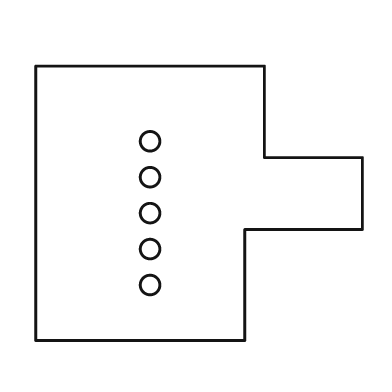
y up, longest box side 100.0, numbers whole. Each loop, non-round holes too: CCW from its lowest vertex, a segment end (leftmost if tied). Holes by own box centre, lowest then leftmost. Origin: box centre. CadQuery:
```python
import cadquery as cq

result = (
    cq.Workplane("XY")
    .moveTo(-50.0, -42.0)
    .lineTo(14.0, -42.0)
    .lineTo(14.0, -8.0)
    .lineTo(50.0, -8.0)
    .lineTo(50.0, 14.0)
    .lineTo(20.0, 14.0)
    .lineTo(20.0, 42.0)
    .lineTo(-50.0, 42.0)
    .close()
    .moveTo(-15.0, -25.0)
    .circle(3.0)
    .moveTo(-15.0, -14.0)
    .circle(3.0)
    .moveTo(-15.0, -3.0)
    .circle(3.0)
    .moveTo(-15.0, 8.0)
    .circle(3.0)
    .moveTo(-15.0, 19.0)
    .circle(3.0)
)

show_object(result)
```